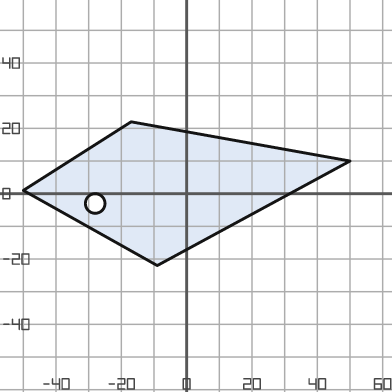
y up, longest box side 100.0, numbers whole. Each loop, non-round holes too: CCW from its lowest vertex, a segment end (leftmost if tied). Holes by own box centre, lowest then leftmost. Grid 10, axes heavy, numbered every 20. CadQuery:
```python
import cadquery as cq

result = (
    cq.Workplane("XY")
    .moveTo(-9.0, -22.0)
    .lineTo(50.0, 10.0)
    .lineTo(-17.0, 22.0)
    .lineTo(-50.0, 1.0)
    .close()
    .moveTo(-28.0, -3.0)
    .circle(3.0)
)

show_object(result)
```